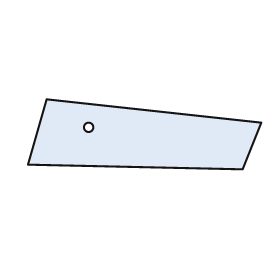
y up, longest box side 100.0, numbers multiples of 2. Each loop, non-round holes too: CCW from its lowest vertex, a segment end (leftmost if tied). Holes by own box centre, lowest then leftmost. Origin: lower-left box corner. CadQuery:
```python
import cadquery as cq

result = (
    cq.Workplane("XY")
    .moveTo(92.0, 0.0)
    .lineTo(100.0, 20.0)
    .lineTo(8.0, 30.0)
    .lineTo(0.0, 2.0)
    .close()
    .moveTo(26.0, 18.0)
    .circle(2.0)
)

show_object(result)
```